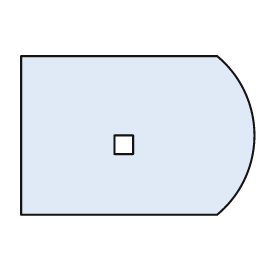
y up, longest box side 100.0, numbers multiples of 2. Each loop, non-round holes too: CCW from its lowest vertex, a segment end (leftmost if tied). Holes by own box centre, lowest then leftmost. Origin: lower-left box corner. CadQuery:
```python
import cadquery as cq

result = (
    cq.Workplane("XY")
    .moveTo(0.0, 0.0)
    .lineTo(84.0, 0.0)
    .threePointArc((100.0, 34.0), (84.0, 68.0))
    .lineTo(0.0, 68.0)
    .close()
    .moveTo(40.0, 26.0)
    .lineTo(48.0, 26.0)
    .lineTo(48.0, 34.0)
    .lineTo(40.0, 34.0)
    .close()
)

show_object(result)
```